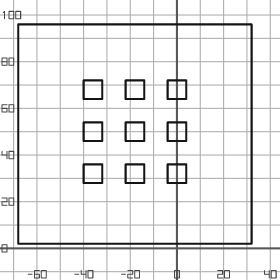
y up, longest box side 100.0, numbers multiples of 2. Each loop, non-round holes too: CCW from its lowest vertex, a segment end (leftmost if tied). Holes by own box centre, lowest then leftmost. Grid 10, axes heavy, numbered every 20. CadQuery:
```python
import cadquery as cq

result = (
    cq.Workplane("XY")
    .moveTo(-68.0, 2.0)
    .lineTo(32.0, 2.0)
    .lineTo(32.0, 96.0)
    .lineTo(-68.0, 96.0)
    .close()
    .moveTo(-40.0, 28.0)
    .lineTo(-32.0, 28.0)
    .lineTo(-32.0, 36.0)
    .lineTo(-40.0, 36.0)
    .close()
    .moveTo(-22.0, 28.0)
    .lineTo(-14.0, 28.0)
    .lineTo(-14.0, 36.0)
    .lineTo(-22.0, 36.0)
    .close()
    .moveTo(-4.0, 28.0)
    .lineTo(4.0, 28.0)
    .lineTo(4.0, 36.0)
    .lineTo(-4.0, 36.0)
    .close()
    .moveTo(-40.0, 46.0)
    .lineTo(-32.0, 46.0)
    .lineTo(-32.0, 54.0)
    .lineTo(-40.0, 54.0)
    .close()
    .moveTo(-22.0, 46.0)
    .lineTo(-14.0, 46.0)
    .lineTo(-14.0, 54.0)
    .lineTo(-22.0, 54.0)
    .close()
    .moveTo(-4.0, 46.0)
    .lineTo(4.0, 46.0)
    .lineTo(4.0, 54.0)
    .lineTo(-4.0, 54.0)
    .close()
    .moveTo(-40.0, 64.0)
    .lineTo(-32.0, 64.0)
    .lineTo(-32.0, 72.0)
    .lineTo(-40.0, 72.0)
    .close()
    .moveTo(-22.0, 64.0)
    .lineTo(-14.0, 64.0)
    .lineTo(-14.0, 72.0)
    .lineTo(-22.0, 72.0)
    .close()
    .moveTo(-4.0, 64.0)
    .lineTo(4.0, 64.0)
    .lineTo(4.0, 72.0)
    .lineTo(-4.0, 72.0)
    .close()
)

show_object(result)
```